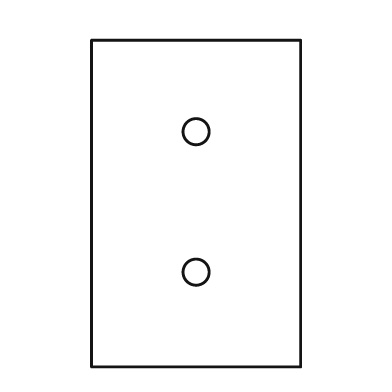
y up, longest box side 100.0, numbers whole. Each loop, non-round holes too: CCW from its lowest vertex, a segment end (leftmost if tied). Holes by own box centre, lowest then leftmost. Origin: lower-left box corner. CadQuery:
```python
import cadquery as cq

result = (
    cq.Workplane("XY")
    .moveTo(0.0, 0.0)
    .lineTo(64.0, 0.0)
    .lineTo(64.0, 100.0)
    .lineTo(0.0, 100.0)
    .close()
    .moveTo(32.0, 29.0)
    .circle(4.0)
    .moveTo(32.0, 72.0)
    .circle(4.0)
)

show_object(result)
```